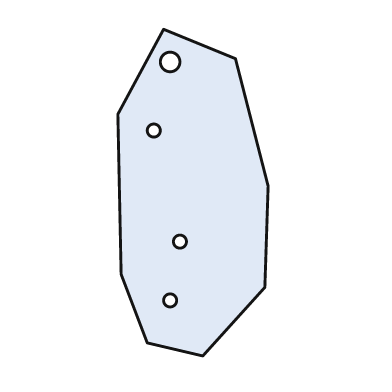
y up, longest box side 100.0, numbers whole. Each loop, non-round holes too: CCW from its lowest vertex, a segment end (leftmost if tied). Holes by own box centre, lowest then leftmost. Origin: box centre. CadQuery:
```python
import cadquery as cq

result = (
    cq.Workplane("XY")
    .moveTo(3.0, -50.0)
    .lineTo(22.0, -29.0)
    .lineTo(23.0, 2.0)
    .lineTo(13.0, 41.0)
    .lineTo(-9.0, 50.0)
    .lineTo(-23.0, 24.0)
    .lineTo(-22.0, -25.0)
    .lineTo(-14.0, -46.0)
    .close()
    .moveTo(-7.0, -33.0)
    .circle(2.0)
    .moveTo(-4.0, -15.0)
    .circle(2.0)
    .moveTo(-12.0, 19.0)
    .circle(2.0)
    .moveTo(-7.0, 40.0)
    .circle(3.0)
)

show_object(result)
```